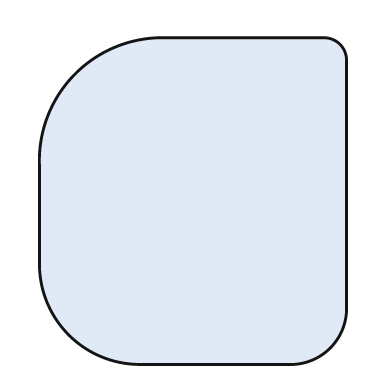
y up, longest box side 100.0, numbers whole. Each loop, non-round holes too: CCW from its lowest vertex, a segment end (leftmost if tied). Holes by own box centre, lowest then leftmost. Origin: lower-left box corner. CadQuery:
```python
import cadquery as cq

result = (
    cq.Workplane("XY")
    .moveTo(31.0, 0.0)
    .lineTo(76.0, 0.0)
    .threePointArc((89.0, 5.0), (94.0, 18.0))
    .lineTo(94.0, 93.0)
    .threePointArc((92.0, 98.0), (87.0, 100.0))
    .lineTo(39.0, 100.0)
    .threePointArc((11.0, 89.0), (0.0, 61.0))
    .lineTo(0.0, 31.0)
    .threePointArc((9.0, 9.0), (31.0, 0.0))
    .close()
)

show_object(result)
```